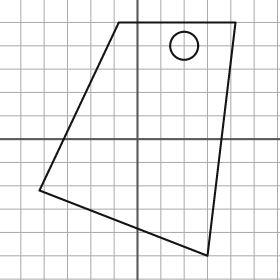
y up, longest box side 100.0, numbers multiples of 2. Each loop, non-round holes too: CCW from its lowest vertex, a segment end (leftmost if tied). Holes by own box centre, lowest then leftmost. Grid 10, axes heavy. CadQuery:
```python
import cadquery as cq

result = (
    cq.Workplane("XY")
    .moveTo(30.0, -50.0)
    .lineTo(42.0, 50.0)
    .lineTo(-8.0, 50.0)
    .lineTo(-42.0, -22.0)
    .close()
    .moveTo(20.0, 40.0)
    .circle(6.0)
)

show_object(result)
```